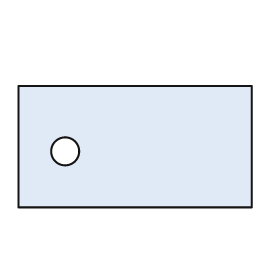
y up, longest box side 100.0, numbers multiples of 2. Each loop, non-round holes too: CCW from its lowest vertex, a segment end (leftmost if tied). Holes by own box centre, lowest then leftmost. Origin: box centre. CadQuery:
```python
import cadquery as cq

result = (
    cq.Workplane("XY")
    .moveTo(-50.0, -26.0)
    .lineTo(50.0, -26.0)
    .lineTo(50.0, 26.0)
    .lineTo(-50.0, 26.0)
    .close()
    .moveTo(-30.0, -2.0)
    .circle(6.0)
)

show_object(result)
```